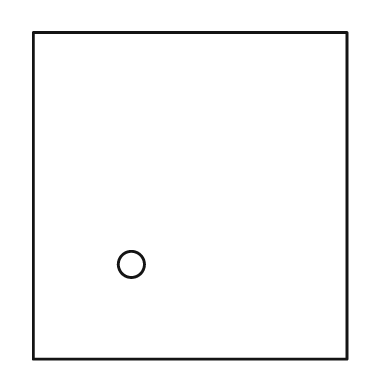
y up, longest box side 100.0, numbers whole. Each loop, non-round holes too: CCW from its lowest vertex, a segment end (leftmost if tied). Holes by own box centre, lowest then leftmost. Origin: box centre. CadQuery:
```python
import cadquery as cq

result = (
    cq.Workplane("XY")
    .moveTo(-48.0, -50.0)
    .lineTo(48.0, -50.0)
    .lineTo(48.0, 50.0)
    .lineTo(-48.0, 50.0)
    .close()
    .moveTo(-18.0, -21.0)
    .circle(4.0)
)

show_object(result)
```